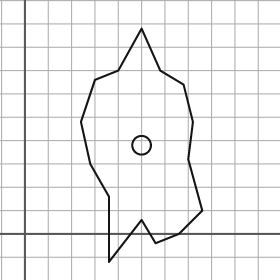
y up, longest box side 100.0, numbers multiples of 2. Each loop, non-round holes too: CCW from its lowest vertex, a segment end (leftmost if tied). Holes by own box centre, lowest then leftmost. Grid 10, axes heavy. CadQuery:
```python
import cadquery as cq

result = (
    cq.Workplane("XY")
    .moveTo(36.0, -12.0)
    .lineTo(50.0, 6.0)
    .lineTo(56.0, -4.0)
    .lineTo(66.0, 0.0)
    .lineTo(76.0, 10.0)
    .lineTo(70.0, 32.0)
    .lineTo(72.0, 48.0)
    .lineTo(68.0, 64.0)
    .lineTo(58.0, 70.0)
    .lineTo(50.0, 88.0)
    .lineTo(40.0, 70.0)
    .lineTo(30.0, 66.0)
    .lineTo(24.0, 48.0)
    .lineTo(28.0, 30.0)
    .lineTo(36.0, 16.0)
    .close()
    .moveTo(50.0, 38.0)
    .circle(4.0)
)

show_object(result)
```